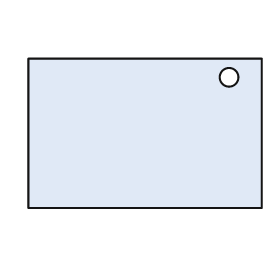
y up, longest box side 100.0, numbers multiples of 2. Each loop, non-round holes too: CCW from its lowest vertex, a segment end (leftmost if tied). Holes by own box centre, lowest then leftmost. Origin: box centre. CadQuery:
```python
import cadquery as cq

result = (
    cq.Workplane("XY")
    .moveTo(-50.0, -32.0)
    .lineTo(50.0, -32.0)
    .lineTo(50.0, 32.0)
    .lineTo(-50.0, 32.0)
    .close()
    .moveTo(36.0, 24.0)
    .circle(4.0)
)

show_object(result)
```